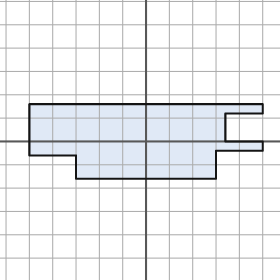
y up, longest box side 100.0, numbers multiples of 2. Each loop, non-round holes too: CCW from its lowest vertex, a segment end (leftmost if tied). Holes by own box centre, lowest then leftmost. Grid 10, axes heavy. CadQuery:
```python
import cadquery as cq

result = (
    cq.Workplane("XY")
    .moveTo(-30.0, -16.0)
    .lineTo(30.0, -16.0)
    .lineTo(30.0, -4.0)
    .lineTo(50.0, -4.0)
    .lineTo(50.0, 0.0)
    .lineTo(34.0, 0.0)
    .lineTo(34.0, 12.0)
    .lineTo(50.0, 12.0)
    .lineTo(50.0, 16.0)
    .lineTo(-50.0, 16.0)
    .lineTo(-50.0, -6.0)
    .lineTo(-30.0, -6.0)
    .close()
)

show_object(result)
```